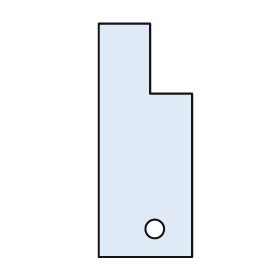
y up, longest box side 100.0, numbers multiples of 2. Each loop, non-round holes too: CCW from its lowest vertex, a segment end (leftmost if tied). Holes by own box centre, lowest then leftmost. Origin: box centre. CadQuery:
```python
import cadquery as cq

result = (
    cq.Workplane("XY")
    .moveTo(-20.0, -50.0)
    .lineTo(20.0, -50.0)
    .lineTo(20.0, 20.0)
    .lineTo(2.0, 20.0)
    .lineTo(2.0, 50.0)
    .lineTo(-20.0, 50.0)
    .close()
    .moveTo(4.0, -38.0)
    .circle(4.0)
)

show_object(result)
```